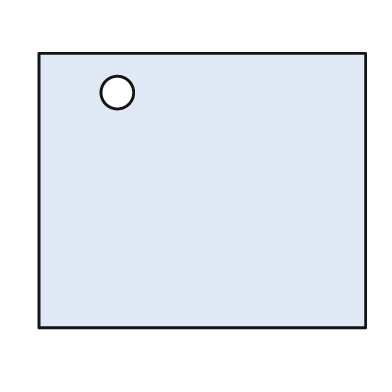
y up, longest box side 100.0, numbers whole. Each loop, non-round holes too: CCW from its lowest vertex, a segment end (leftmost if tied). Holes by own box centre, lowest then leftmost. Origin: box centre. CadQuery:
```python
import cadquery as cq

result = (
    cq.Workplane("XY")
    .moveTo(-50.0, -42.0)
    .lineTo(50.0, -42.0)
    .lineTo(50.0, 42.0)
    .lineTo(-50.0, 42.0)
    .close()
    .moveTo(-26.0, 30.0)
    .circle(5.0)
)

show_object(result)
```